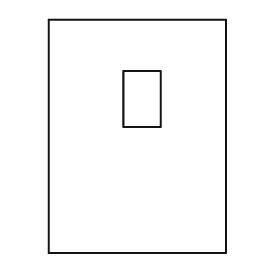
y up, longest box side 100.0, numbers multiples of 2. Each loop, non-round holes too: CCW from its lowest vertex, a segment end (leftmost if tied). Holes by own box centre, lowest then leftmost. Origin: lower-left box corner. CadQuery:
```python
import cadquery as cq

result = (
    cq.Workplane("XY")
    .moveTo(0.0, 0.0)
    .lineTo(76.0, 0.0)
    .lineTo(76.0, 100.0)
    .lineTo(0.0, 100.0)
    .close()
    .moveTo(32.0, 54.0)
    .lineTo(48.0, 54.0)
    .lineTo(48.0, 78.0)
    .lineTo(32.0, 78.0)
    .close()
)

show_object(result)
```